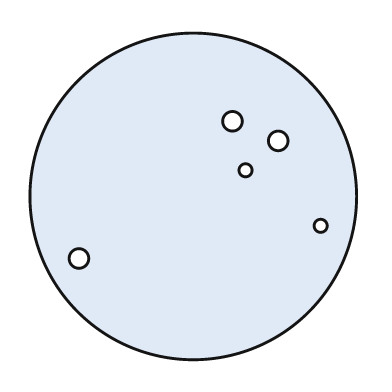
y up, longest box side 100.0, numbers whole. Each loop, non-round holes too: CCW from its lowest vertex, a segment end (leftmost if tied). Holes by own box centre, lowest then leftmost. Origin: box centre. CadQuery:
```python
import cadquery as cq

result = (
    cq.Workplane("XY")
    .moveTo(0.0, 0.0)
    .circle(50.0)
    .moveTo(-35.0, -19.0)
    .circle(3.0)
    .moveTo(39.0, -9.0)
    .circle(2.0)
    .moveTo(16.0, 8.0)
    .circle(2.0)
    .moveTo(26.0, 17.0)
    .circle(3.0)
    .moveTo(12.0, 23.0)
    .circle(3.0)
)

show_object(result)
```